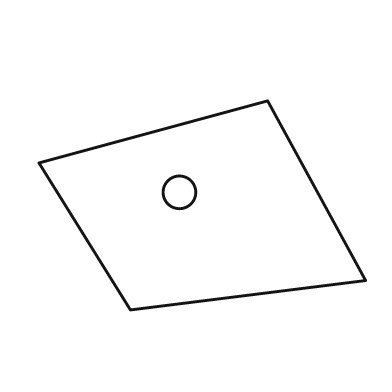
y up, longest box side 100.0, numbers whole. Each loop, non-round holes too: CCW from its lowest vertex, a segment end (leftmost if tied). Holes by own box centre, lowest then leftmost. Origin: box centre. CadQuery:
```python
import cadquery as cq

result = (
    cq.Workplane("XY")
    .moveTo(-22.0, -32.0)
    .lineTo(50.0, -23.0)
    .lineTo(20.0, 32.0)
    .lineTo(-50.0, 13.0)
    .close()
    .moveTo(-7.0, 4.0)
    .circle(5.0)
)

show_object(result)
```